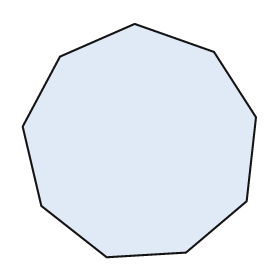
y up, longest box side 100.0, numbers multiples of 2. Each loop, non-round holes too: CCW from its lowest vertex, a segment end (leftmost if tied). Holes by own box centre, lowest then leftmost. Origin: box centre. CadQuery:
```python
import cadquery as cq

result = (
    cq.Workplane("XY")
    .moveTo(-14.0, -50.0)
    .lineTo(20.0, -48.0)
    .lineTo(46.0, -26.0)
    .lineTo(50.0, 10.0)
    .lineTo(32.0, 38.0)
    .lineTo(-2.0, 50.0)
    .lineTo(-34.0, 36.0)
    .lineTo(-50.0, 6.0)
    .lineTo(-42.0, -28.0)
    .close()
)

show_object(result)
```